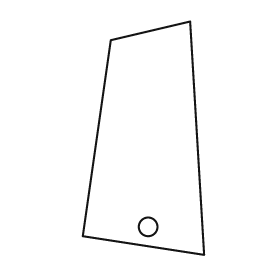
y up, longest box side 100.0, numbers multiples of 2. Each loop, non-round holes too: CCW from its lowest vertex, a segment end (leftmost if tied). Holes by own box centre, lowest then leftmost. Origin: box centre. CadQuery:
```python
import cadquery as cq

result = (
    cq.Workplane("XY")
    .moveTo(26.0, -50.0)
    .lineTo(20.0, 50.0)
    .lineTo(-14.0, 42.0)
    .lineTo(-26.0, -42.0)
    .close()
    .moveTo(2.0, -38.0)
    .circle(4.0)
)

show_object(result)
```